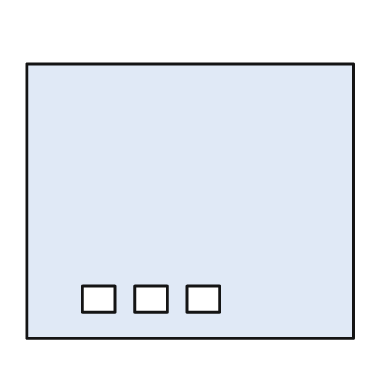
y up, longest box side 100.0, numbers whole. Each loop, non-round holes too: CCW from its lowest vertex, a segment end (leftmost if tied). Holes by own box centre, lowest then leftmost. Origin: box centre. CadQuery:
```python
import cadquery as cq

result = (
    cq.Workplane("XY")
    .moveTo(-50.0, -42.0)
    .lineTo(50.0, -42.0)
    .lineTo(50.0, 42.0)
    .lineTo(-50.0, 42.0)
    .close()
    .moveTo(-33.0, -34.0)
    .lineTo(-23.0, -34.0)
    .lineTo(-23.0, -26.0)
    .lineTo(-33.0, -26.0)
    .close()
    .moveTo(-17.0, -34.0)
    .lineTo(-7.0, -34.0)
    .lineTo(-7.0, -26.0)
    .lineTo(-17.0, -26.0)
    .close()
    .moveTo(-1.0, -34.0)
    .lineTo(9.0, -34.0)
    .lineTo(9.0, -26.0)
    .lineTo(-1.0, -26.0)
    .close()
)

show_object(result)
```